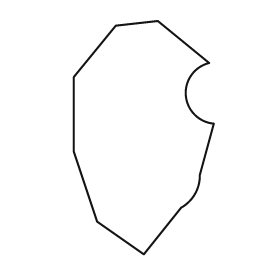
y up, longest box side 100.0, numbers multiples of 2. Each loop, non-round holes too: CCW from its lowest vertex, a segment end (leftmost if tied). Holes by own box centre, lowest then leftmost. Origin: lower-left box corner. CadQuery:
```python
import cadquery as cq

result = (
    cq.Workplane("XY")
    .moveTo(30.0, 0.0)
    .lineTo(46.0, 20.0)
    .threePointArc((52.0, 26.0), (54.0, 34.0))
    .lineTo(60.0, 56.0)
    .threePointArc((48.0, 68.0), (58.0, 82.0))
    .lineTo(36.0, 100.0)
    .lineTo(18.0, 98.0)
    .lineTo(0.0, 76.0)
    .lineTo(0.0, 44.0)
    .lineTo(10.0, 14.0)
    .close()
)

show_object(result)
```